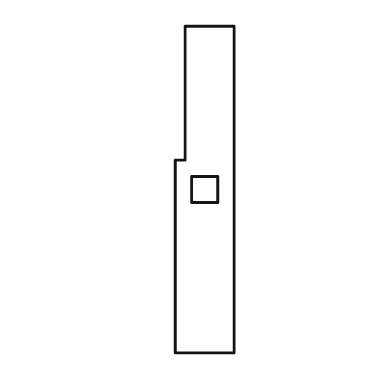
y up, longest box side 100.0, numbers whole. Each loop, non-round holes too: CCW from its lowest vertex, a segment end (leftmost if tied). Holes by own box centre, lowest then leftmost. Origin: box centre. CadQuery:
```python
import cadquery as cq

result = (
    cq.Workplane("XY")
    .moveTo(-9.0, -50.0)
    .lineTo(9.0, -50.0)
    .lineTo(9.0, 50.0)
    .lineTo(-6.0, 50.0)
    .lineTo(-6.0, 9.0)
    .lineTo(-9.0, 9.0)
    .close()
    .moveTo(-4.0, -4.0)
    .lineTo(4.0, -4.0)
    .lineTo(4.0, 4.0)
    .lineTo(-4.0, 4.0)
    .close()
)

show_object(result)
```